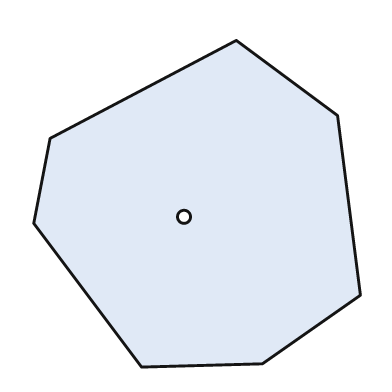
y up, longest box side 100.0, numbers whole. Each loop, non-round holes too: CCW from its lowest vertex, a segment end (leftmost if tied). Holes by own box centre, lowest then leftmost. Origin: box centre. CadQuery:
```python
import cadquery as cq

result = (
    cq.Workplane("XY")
    .moveTo(-17.0, -50.0)
    .lineTo(20.0, -49.0)
    .lineTo(50.0, -28.0)
    .lineTo(43.0, 27.0)
    .lineTo(12.0, 50.0)
    .lineTo(-45.0, 20.0)
    .lineTo(-50.0, -6.0)
    .close()
    .moveTo(-4.0, -4.0)
    .circle(2.0)
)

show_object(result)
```